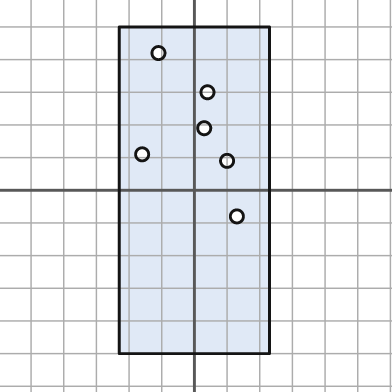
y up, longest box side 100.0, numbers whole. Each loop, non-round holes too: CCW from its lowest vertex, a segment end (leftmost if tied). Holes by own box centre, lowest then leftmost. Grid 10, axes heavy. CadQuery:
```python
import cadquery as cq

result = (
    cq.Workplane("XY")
    .moveTo(-23.0, -50.0)
    .lineTo(23.0, -50.0)
    .lineTo(23.0, 50.0)
    .lineTo(-23.0, 50.0)
    .close()
    .moveTo(13.0, -8.0)
    .circle(2.0)
    .moveTo(10.0, 9.0)
    .circle(2.0)
    .moveTo(-16.0, 11.0)
    .circle(2.0)
    .moveTo(3.0, 19.0)
    .circle(2.0)
    .moveTo(4.0, 30.0)
    .circle(2.0)
    .moveTo(-11.0, 42.0)
    .circle(2.0)
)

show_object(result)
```